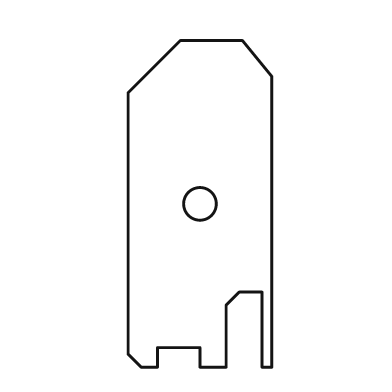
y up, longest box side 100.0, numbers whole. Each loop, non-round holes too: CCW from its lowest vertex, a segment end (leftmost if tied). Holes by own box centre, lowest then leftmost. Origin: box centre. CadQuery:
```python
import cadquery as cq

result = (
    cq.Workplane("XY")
    .moveTo(-18.0, -50.0)
    .lineTo(-13.0, -50.0)
    .lineTo(-13.0, -44.0)
    .lineTo(0.0, -44.0)
    .lineTo(0.0, -50.0)
    .lineTo(8.0, -50.0)
    .lineTo(8.0, -31.0)
    .lineTo(12.0, -27.0)
    .lineTo(19.0, -27.0)
    .lineTo(19.0, -50.0)
    .lineTo(22.0, -50.0)
    .lineTo(22.0, 39.0)
    .lineTo(13.0, 50.0)
    .lineTo(-6.0, 50.0)
    .lineTo(-22.0, 34.0)
    .lineTo(-22.0, -46.0)
    .close()
    .moveTo(0.0, 0.0)
    .circle(5.0)
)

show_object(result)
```